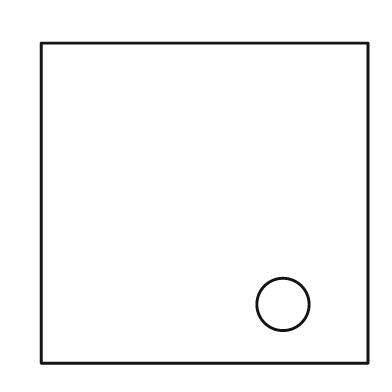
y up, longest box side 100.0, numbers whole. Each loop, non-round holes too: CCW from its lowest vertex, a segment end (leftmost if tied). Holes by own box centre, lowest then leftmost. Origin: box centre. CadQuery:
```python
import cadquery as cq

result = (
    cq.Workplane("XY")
    .moveTo(-50.0, -49.0)
    .lineTo(50.0, -49.0)
    .lineTo(50.0, 49.0)
    .lineTo(-50.0, 49.0)
    .close()
    .moveTo(24.0, -31.0)
    .circle(8.0)
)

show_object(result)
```